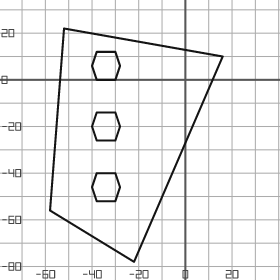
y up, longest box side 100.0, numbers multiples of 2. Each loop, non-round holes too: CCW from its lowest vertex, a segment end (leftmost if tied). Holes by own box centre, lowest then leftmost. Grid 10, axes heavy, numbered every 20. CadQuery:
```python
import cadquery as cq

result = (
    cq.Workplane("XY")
    .moveTo(-22.0, -78.0)
    .lineTo(16.0, 10.0)
    .lineTo(-52.0, 22.0)
    .lineTo(-58.0, -56.0)
    .close()
    .moveTo(-38.0, -52.0)
    .lineTo(-30.0, -52.0)
    .lineTo(-28.0, -46.0)
    .lineTo(-30.0, -40.0)
    .lineTo(-38.0, -40.0)
    .lineTo(-40.0, -46.0)
    .close()
    .moveTo(-38.0, -26.0)
    .lineTo(-30.0, -26.0)
    .lineTo(-28.0, -20.0)
    .lineTo(-30.0, -14.0)
    .lineTo(-38.0, -14.0)
    .lineTo(-40.0, -20.0)
    .close()
    .moveTo(-38.0, 0.0)
    .lineTo(-30.0, 0.0)
    .lineTo(-28.0, 6.0)
    .lineTo(-30.0, 12.0)
    .lineTo(-38.0, 12.0)
    .lineTo(-40.0, 6.0)
    .close()
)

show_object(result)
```